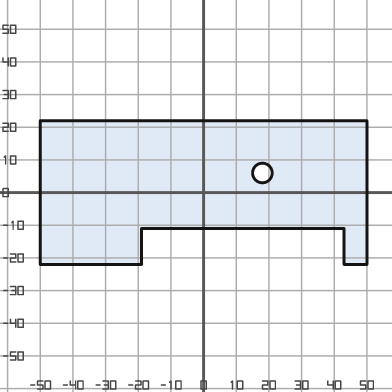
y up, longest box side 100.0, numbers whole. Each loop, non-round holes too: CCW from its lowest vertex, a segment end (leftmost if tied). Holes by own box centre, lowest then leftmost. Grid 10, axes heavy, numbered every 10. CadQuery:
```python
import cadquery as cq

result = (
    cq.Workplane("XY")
    .moveTo(-50.0, -22.0)
    .lineTo(-19.0, -22.0)
    .lineTo(-19.0, -11.0)
    .lineTo(43.0, -11.0)
    .lineTo(43.0, -22.0)
    .lineTo(50.0, -22.0)
    .lineTo(50.0, 22.0)
    .lineTo(-50.0, 22.0)
    .close()
    .moveTo(18.0, 6.0)
    .circle(3.0)
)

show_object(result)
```